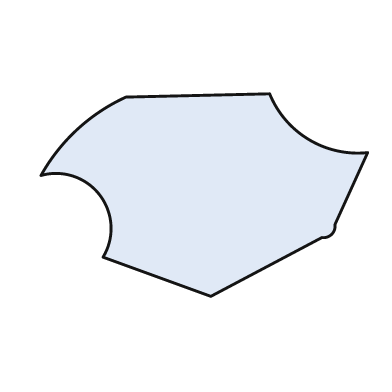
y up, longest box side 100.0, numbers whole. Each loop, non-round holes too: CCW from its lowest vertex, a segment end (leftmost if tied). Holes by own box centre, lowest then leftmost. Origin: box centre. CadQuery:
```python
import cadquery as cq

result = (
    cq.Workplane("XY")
    .moveTo(2.0, -31.0)
    .lineTo(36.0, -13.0)
    .threePointArc((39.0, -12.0), (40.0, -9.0))
    .lineTo(50.0, 13.0)
    .threePointArc((32.0, 17.0), (20.0, 31.0))
    .lineTo(-24.0, 30.0)
    .threePointArc((-39.0, 20.0), (-50.0, 6.0))
    .threePointArc((-32.0, 0.0), (-31.0, -19.0))
    .close()
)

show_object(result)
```